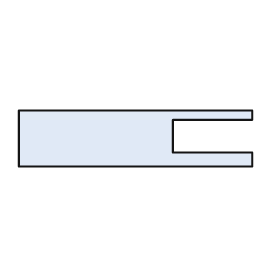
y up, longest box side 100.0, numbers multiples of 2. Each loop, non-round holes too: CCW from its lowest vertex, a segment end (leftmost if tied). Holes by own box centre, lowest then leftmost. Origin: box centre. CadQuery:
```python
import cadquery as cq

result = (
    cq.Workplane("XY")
    .moveTo(-50.0, -12.0)
    .lineTo(50.0, -12.0)
    .lineTo(50.0, -6.0)
    .lineTo(16.0, -6.0)
    .lineTo(16.0, 8.0)
    .lineTo(50.0, 8.0)
    .lineTo(50.0, 12.0)
    .lineTo(-50.0, 12.0)
    .close()
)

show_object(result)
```